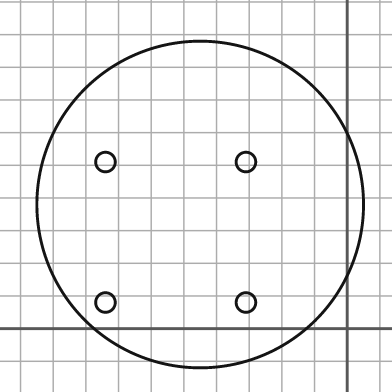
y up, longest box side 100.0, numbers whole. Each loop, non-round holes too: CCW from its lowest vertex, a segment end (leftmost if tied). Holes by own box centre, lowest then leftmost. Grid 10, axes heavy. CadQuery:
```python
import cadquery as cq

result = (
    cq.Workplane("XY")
    .moveTo(-45.0, 38.0)
    .circle(50.0)
    .moveTo(-74.0, 8.0)
    .circle(3.0)
    .moveTo(-31.0, 8.0)
    .circle(3.0)
    .moveTo(-74.0, 51.0)
    .circle(3.0)
    .moveTo(-31.0, 51.0)
    .circle(3.0)
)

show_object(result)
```